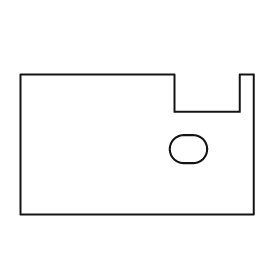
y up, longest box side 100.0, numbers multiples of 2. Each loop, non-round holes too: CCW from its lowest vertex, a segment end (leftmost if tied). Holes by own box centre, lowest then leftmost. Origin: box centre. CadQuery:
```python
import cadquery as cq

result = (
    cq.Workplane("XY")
    .moveTo(-50.0, -30.0)
    .lineTo(50.0, -30.0)
    .lineTo(50.0, 30.0)
    .lineTo(44.0, 30.0)
    .lineTo(44.0, 14.0)
    .lineTo(16.0, 14.0)
    .lineTo(16.0, 30.0)
    .lineTo(-50.0, 30.0)
    .close()
    .moveTo(20.0, -8.0)
    .lineTo(24.0, -8.0)
    .threePointArc((30.0, -2.0), (24.0, 4.0))
    .lineTo(20.0, 4.0)
    .threePointArc((14.0, -2.0), (20.0, -8.0))
    .close()
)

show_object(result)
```